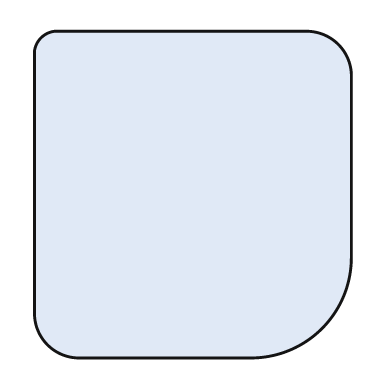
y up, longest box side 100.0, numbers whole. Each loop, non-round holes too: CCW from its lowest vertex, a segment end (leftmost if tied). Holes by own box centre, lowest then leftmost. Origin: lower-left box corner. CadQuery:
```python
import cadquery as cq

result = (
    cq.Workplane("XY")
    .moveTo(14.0, 0.0)
    .lineTo(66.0, 0.0)
    .threePointArc((88.0, 9.0), (97.0, 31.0))
    .lineTo(97.0, 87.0)
    .threePointArc((93.0, 96.0), (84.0, 100.0))
    .lineTo(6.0, 100.0)
    .threePointArc((2.0, 98.0), (0.0, 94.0))
    .lineTo(0.0, 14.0)
    .threePointArc((4.0, 4.0), (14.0, 0.0))
    .close()
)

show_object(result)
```